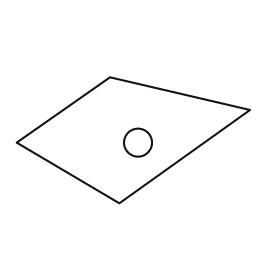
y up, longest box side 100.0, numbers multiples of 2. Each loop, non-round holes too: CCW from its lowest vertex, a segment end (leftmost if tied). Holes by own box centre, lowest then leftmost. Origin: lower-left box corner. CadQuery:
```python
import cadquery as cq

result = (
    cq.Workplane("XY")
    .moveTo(44.0, 0.0)
    .lineTo(100.0, 40.0)
    .lineTo(40.0, 54.0)
    .lineTo(0.0, 26.0)
    .close()
    .moveTo(52.0, 26.0)
    .circle(6.0)
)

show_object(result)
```